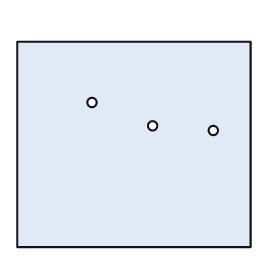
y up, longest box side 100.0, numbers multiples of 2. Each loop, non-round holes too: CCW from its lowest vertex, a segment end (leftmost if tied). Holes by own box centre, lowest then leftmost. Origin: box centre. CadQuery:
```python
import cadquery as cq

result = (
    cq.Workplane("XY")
    .moveTo(-50.0, -44.0)
    .lineTo(50.0, -44.0)
    .lineTo(50.0, 44.0)
    .lineTo(-50.0, 44.0)
    .close()
    .moveTo(34.0, 6.0)
    .circle(2.0)
    .moveTo(8.0, 8.0)
    .circle(2.0)
    .moveTo(-18.0, 18.0)
    .circle(2.0)
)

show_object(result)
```